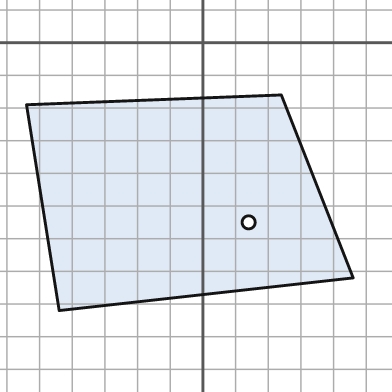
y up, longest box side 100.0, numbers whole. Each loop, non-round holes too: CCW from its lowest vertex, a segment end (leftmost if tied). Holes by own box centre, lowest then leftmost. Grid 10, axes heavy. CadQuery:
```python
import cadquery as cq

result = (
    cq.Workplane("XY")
    .moveTo(-44.0, -82.0)
    .lineTo(46.0, -72.0)
    .lineTo(24.0, -16.0)
    .lineTo(-54.0, -19.0)
    .close()
    .moveTo(14.0, -55.0)
    .circle(2.0)
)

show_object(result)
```